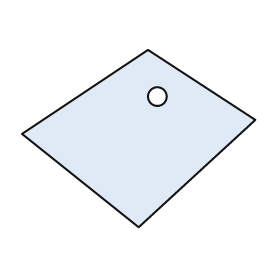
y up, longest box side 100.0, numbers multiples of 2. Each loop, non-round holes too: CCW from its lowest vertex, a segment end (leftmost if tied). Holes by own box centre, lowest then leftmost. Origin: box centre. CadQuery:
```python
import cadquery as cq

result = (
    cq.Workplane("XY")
    .moveTo(0.0, -38.0)
    .lineTo(50.0, 8.0)
    .lineTo(4.0, 38.0)
    .lineTo(-50.0, 2.0)
    .close()
    .moveTo(8.0, 18.0)
    .circle(4.0)
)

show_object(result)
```